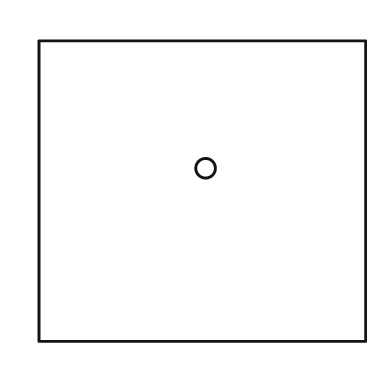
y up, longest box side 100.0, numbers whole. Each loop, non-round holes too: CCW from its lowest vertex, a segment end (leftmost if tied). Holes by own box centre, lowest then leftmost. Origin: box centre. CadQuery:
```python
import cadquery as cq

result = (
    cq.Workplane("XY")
    .moveTo(-50.0, -46.0)
    .lineTo(50.0, -46.0)
    .lineTo(50.0, 46.0)
    .lineTo(-50.0, 46.0)
    .close()
    .moveTo(1.0, 7.0)
    .circle(3.0)
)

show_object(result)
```